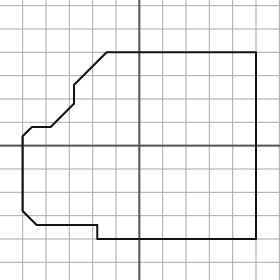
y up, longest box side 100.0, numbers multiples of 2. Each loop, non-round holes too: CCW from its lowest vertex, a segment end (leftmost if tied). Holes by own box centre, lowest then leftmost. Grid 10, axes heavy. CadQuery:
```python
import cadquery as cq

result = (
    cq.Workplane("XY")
    .moveTo(-18.0, -40.0)
    .lineTo(50.0, -40.0)
    .lineTo(50.0, 40.0)
    .lineTo(-14.0, 40.0)
    .lineTo(-28.0, 26.0)
    .lineTo(-28.0, 18.0)
    .lineTo(-38.0, 8.0)
    .lineTo(-46.0, 8.0)
    .lineTo(-50.0, 4.0)
    .lineTo(-50.0, -28.0)
    .lineTo(-44.0, -34.0)
    .lineTo(-18.0, -34.0)
    .close()
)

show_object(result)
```